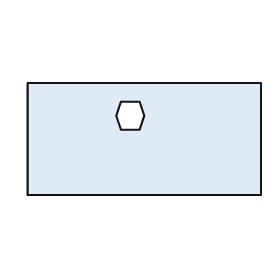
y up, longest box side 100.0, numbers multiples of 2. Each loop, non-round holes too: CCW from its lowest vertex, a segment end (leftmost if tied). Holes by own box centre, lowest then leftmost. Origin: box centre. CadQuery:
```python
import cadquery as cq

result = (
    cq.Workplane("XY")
    .moveTo(-50.0, -24.0)
    .lineTo(50.0, -24.0)
    .lineTo(50.0, 24.0)
    .lineTo(-50.0, 24.0)
    .close()
    .moveTo(-10.0, 4.0)
    .lineTo(-2.0, 4.0)
    .lineTo(0.0, 10.0)
    .lineTo(-2.0, 16.0)
    .lineTo(-10.0, 16.0)
    .lineTo(-12.0, 10.0)
    .close()
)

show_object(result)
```